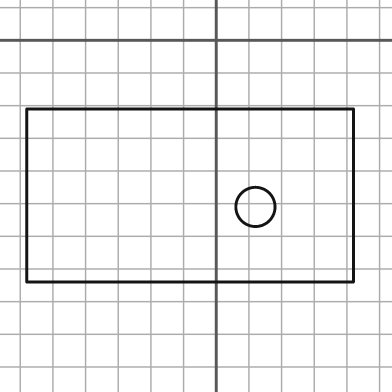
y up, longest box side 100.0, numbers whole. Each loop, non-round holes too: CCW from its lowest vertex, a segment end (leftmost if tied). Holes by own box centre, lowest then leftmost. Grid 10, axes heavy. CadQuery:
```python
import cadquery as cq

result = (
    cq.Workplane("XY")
    .moveTo(-58.0, -74.0)
    .lineTo(42.0, -74.0)
    .lineTo(42.0, -21.0)
    .lineTo(-58.0, -21.0)
    .close()
    .moveTo(12.0, -51.0)
    .circle(6.0)
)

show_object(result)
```